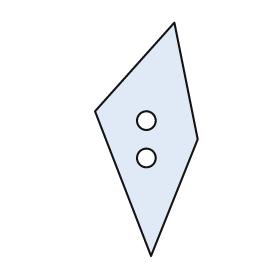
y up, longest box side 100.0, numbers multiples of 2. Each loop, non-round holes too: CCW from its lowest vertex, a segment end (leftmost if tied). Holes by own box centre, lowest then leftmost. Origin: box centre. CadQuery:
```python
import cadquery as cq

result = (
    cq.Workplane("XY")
    .moveTo(2.0, -50.0)
    .lineTo(22.0, 0.0)
    .lineTo(12.0, 50.0)
    .lineTo(-22.0, 12.0)
    .close()
    .moveTo(0.0, -8.0)
    .circle(4.0)
    .moveTo(0.0, 8.0)
    .circle(4.0)
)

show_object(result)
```